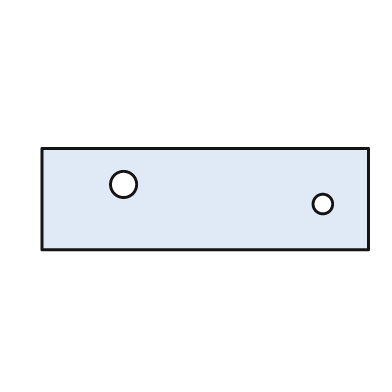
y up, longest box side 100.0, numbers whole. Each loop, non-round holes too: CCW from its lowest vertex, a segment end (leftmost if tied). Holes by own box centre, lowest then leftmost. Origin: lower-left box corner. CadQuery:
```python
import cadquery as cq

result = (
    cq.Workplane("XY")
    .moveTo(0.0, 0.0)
    .lineTo(100.0, 0.0)
    .lineTo(100.0, 31.0)
    .lineTo(0.0, 31.0)
    .close()
    .moveTo(86.0, 14.0)
    .circle(3.0)
    .moveTo(25.0, 20.0)
    .circle(4.0)
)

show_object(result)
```